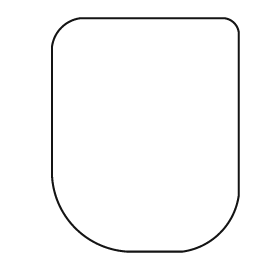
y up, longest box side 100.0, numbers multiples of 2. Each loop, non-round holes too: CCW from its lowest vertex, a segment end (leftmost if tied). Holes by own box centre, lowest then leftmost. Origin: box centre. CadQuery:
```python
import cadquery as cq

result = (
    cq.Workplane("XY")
    .moveTo(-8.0, -50.0)
    .lineTo(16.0, -50.0)
    .threePointArc((32.0, -42.0), (40.0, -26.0))
    .lineTo(40.0, 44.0)
    .threePointArc((38.0, 48.0), (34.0, 50.0))
    .lineTo(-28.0, 50.0)
    .threePointArc((-36.0, 46.0), (-40.0, 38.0))
    .lineTo(-40.0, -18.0)
    .threePointArc((-30.0, -40.0), (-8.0, -50.0))
    .close()
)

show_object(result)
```